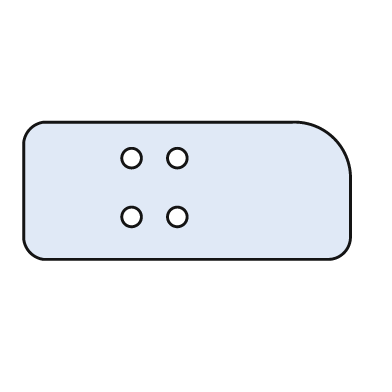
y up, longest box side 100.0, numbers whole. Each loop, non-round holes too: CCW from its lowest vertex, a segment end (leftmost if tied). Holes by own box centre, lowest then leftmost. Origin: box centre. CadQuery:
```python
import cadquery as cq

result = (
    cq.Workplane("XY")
    .moveTo(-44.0, -21.0)
    .lineTo(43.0, -21.0)
    .threePointArc((48.0, -19.0), (50.0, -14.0))
    .lineTo(50.0, 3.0)
    .threePointArc((45.0, 16.0), (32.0, 21.0))
    .lineTo(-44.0, 21.0)
    .threePointArc((-48.0, 19.0), (-50.0, 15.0))
    .lineTo(-50.0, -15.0)
    .threePointArc((-48.0, -19.0), (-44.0, -21.0))
    .close()
    .moveTo(-17.0, -8.0)
    .circle(3.0)
    .moveTo(-3.0, -8.0)
    .circle(3.0)
    .moveTo(-17.0, 10.0)
    .circle(3.0)
    .moveTo(-3.0, 10.0)
    .circle(3.0)
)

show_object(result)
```